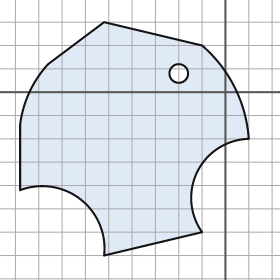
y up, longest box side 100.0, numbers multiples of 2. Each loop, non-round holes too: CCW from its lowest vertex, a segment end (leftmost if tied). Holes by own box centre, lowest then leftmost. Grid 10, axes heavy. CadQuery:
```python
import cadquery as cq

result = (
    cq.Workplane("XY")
    .moveTo(-52.0, -70.0)
    .lineTo(-10.0, -60.0)
    .threePointArc((-12.0, -34.0), (10.0, -20.0))
    .threePointArc((4.0, 2.0), (-10.0, 20.0))
    .lineTo(-52.0, 30.0)
    .lineTo(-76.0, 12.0)
    .threePointArc((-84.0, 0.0), (-88.0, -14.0))
    .lineTo(-88.0, -42.0)
    .threePointArc((-62.0, -46.0), (-52.0, -70.0))
    .close()
    .moveTo(-20.0, 8.0)
    .circle(4.0)
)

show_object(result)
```